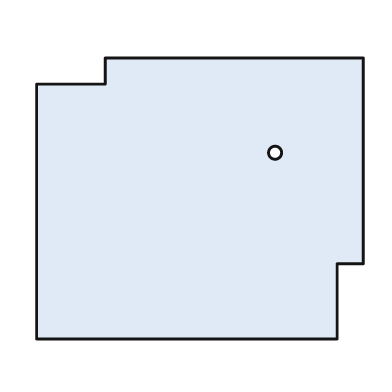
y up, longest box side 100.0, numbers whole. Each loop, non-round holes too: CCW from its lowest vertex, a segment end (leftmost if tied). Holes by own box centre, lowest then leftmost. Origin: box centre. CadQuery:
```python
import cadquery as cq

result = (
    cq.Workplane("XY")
    .moveTo(-50.0, -43.0)
    .lineTo(42.0, -43.0)
    .lineTo(42.0, -20.0)
    .lineTo(50.0, -20.0)
    .lineTo(50.0, 43.0)
    .lineTo(-29.0, 43.0)
    .lineTo(-29.0, 35.0)
    .lineTo(-50.0, 35.0)
    .close()
    .moveTo(23.0, 14.0)
    .circle(2.0)
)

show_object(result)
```